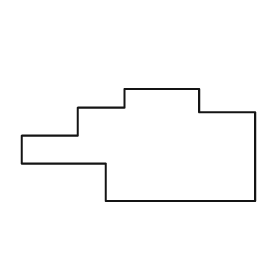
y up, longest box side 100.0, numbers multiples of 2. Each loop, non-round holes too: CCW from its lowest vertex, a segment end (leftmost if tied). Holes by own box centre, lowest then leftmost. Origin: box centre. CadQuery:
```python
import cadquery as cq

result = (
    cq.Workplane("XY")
    .moveTo(-14.0, -24.0)
    .lineTo(50.0, -24.0)
    .lineTo(50.0, 14.0)
    .lineTo(26.0, 14.0)
    .lineTo(26.0, 24.0)
    .lineTo(-6.0, 24.0)
    .lineTo(-6.0, 16.0)
    .lineTo(-26.0, 16.0)
    .lineTo(-26.0, 4.0)
    .lineTo(-50.0, 4.0)
    .lineTo(-50.0, -8.0)
    .lineTo(-14.0, -8.0)
    .close()
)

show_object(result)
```